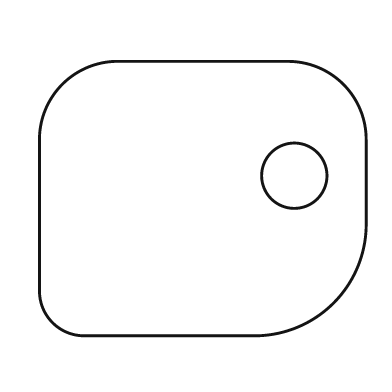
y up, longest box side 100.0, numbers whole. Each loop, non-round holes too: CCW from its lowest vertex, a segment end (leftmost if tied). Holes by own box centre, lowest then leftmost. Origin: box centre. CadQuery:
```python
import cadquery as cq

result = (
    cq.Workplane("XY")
    .moveTo(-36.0, -42.0)
    .lineTo(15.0, -42.0)
    .threePointArc((40.0, -32.0), (50.0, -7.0))
    .lineTo(50.0, 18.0)
    .threePointArc((43.0, 35.0), (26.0, 42.0))
    .lineTo(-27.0, 42.0)
    .threePointArc((-43.0, 35.0), (-50.0, 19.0))
    .lineTo(-50.0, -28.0)
    .threePointArc((-46.0, -38.0), (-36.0, -42.0))
    .close()
    .moveTo(28.0, 7.0)
    .circle(10.0)
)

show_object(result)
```